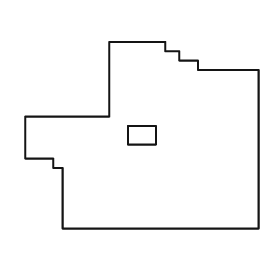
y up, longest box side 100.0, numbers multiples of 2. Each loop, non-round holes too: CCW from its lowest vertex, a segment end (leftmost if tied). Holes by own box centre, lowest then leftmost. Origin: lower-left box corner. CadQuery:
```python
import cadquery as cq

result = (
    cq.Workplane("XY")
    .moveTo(16.0, 0.0)
    .lineTo(100.0, 0.0)
    .lineTo(100.0, 68.0)
    .lineTo(74.0, 68.0)
    .lineTo(74.0, 72.0)
    .lineTo(66.0, 72.0)
    .lineTo(66.0, 76.0)
    .lineTo(60.0, 76.0)
    .lineTo(60.0, 80.0)
    .lineTo(36.0, 80.0)
    .lineTo(36.0, 48.0)
    .lineTo(0.0, 48.0)
    .lineTo(0.0, 30.0)
    .lineTo(12.0, 30.0)
    .lineTo(12.0, 26.0)
    .lineTo(16.0, 26.0)
    .close()
    .moveTo(44.0, 36.0)
    .lineTo(56.0, 36.0)
    .lineTo(56.0, 44.0)
    .lineTo(44.0, 44.0)
    .close()
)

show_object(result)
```